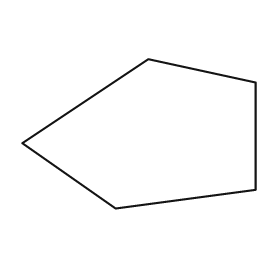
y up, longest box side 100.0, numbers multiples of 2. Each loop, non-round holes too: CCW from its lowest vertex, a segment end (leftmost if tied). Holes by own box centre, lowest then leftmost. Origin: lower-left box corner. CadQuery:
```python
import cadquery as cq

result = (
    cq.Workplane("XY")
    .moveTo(40.0, 0.0)
    .lineTo(100.0, 8.0)
    .lineTo(100.0, 54.0)
    .lineTo(54.0, 64.0)
    .lineTo(0.0, 28.0)
    .close()
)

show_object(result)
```